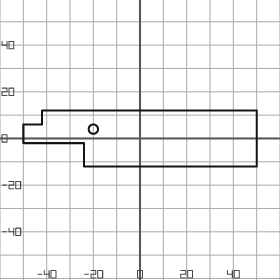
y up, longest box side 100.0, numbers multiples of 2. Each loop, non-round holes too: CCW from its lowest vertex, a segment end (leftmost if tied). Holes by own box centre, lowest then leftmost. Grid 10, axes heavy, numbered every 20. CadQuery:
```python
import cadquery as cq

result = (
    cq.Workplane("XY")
    .moveTo(-24.0, -12.0)
    .lineTo(50.0, -12.0)
    .lineTo(50.0, 12.0)
    .lineTo(-42.0, 12.0)
    .lineTo(-42.0, 6.0)
    .lineTo(-50.0, 6.0)
    .lineTo(-50.0, -2.0)
    .lineTo(-24.0, -2.0)
    .close()
    .moveTo(-20.0, 4.0)
    .circle(2.0)
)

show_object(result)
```